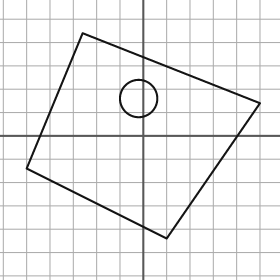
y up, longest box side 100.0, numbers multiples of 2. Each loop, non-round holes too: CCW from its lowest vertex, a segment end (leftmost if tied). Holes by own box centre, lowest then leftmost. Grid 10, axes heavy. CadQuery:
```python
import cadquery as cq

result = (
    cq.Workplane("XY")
    .moveTo(10.0, -44.0)
    .lineTo(50.0, 14.0)
    .lineTo(-26.0, 44.0)
    .lineTo(-50.0, -14.0)
    .close()
    .moveTo(-2.0, 16.0)
    .circle(8.0)
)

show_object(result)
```